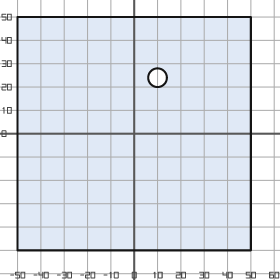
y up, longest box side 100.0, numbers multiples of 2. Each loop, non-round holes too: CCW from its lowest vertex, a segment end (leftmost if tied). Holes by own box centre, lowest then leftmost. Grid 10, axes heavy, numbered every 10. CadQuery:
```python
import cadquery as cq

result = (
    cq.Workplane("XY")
    .moveTo(-50.0, -50.0)
    .lineTo(50.0, -50.0)
    .lineTo(50.0, 50.0)
    .lineTo(-50.0, 50.0)
    .close()
    .moveTo(10.0, 24.0)
    .circle(4.0)
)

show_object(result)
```